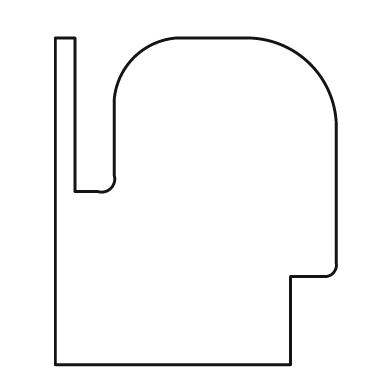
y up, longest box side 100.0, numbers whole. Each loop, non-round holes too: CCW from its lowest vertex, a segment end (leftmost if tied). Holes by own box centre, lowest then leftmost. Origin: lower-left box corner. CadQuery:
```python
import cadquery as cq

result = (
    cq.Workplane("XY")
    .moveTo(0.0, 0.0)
    .lineTo(72.0, 0.0)
    .lineTo(72.0, 27.0)
    .lineTo(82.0, 27.0)
    .threePointArc((85.0, 28.0), (86.0, 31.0))
    .lineTo(86.0, 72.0)
    .threePointArc((78.0, 92.0), (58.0, 100.0))
    .lineTo(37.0, 100.0)
    .threePointArc((24.0, 94.0), (18.0, 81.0))
    .lineTo(18.0, 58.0)
    .threePointArc((17.0, 54.0), (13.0, 53.0))
    .lineTo(6.0, 53.0)
    .lineTo(6.0, 100.0)
    .lineTo(0.0, 100.0)
    .close()
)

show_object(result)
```